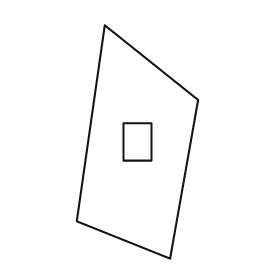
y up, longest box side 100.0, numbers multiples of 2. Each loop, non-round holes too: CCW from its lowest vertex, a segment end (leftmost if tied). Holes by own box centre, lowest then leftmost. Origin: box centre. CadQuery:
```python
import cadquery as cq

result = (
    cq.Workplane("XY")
    .moveTo(14.0, -50.0)
    .lineTo(26.0, 18.0)
    .lineTo(-14.0, 50.0)
    .lineTo(-26.0, -34.0)
    .close()
    .moveTo(-6.0, -8.0)
    .lineTo(6.0, -8.0)
    .lineTo(6.0, 8.0)
    .lineTo(-6.0, 8.0)
    .close()
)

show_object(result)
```